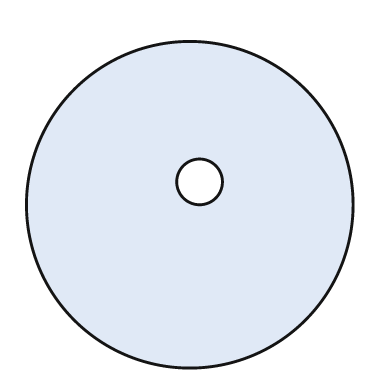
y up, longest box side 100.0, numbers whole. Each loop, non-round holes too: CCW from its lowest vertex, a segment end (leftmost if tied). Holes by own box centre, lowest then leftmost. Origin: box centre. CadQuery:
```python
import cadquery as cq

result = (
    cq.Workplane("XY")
    .moveTo(0.0, 0.0)
    .circle(50.0)
    .moveTo(3.0, 7.0)
    .circle(7.0)
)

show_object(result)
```